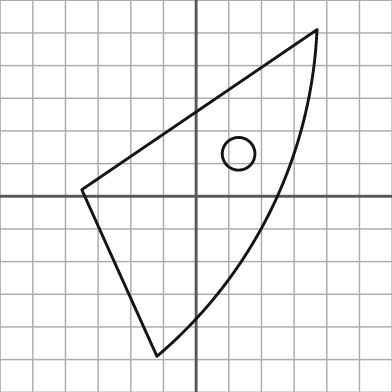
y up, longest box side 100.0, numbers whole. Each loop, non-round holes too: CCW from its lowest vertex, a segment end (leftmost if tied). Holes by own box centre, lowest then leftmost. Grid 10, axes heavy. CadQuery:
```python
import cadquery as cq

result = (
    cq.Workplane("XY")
    .moveTo(-12.0, -49.0)
    .threePointArc((23.0, -4.0), (37.0, 51.0))
    .lineTo(-35.0, 2.0)
    .close()
    .moveTo(13.0, 13.0)
    .circle(5.0)
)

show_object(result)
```